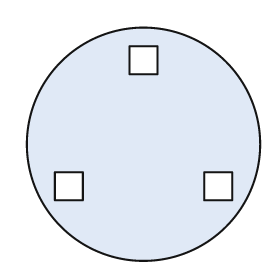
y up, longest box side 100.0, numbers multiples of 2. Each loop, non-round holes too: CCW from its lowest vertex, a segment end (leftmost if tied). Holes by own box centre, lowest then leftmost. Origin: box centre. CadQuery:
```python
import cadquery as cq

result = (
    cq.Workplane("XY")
    .moveTo(0.0, 0.0)
    .circle(50.0)
    .moveTo(-38.0, -24.0)
    .lineTo(-26.0, -24.0)
    .lineTo(-26.0, -12.0)
    .lineTo(-38.0, -12.0)
    .close()
    .moveTo(26.0, -24.0)
    .lineTo(38.0, -24.0)
    .lineTo(38.0, -12.0)
    .lineTo(26.0, -12.0)
    .close()
    .moveTo(-6.0, 30.0)
    .lineTo(6.0, 30.0)
    .lineTo(6.0, 42.0)
    .lineTo(-6.0, 42.0)
    .close()
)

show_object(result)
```